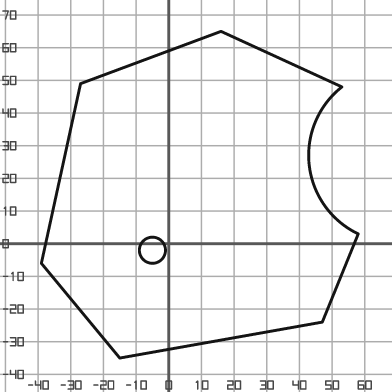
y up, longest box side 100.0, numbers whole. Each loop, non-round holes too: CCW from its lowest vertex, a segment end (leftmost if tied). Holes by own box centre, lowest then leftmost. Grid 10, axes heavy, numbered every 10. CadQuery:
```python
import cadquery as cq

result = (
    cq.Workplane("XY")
    .moveTo(-15.0, -35.0)
    .lineTo(47.0, -24.0)
    .lineTo(58.0, 3.0)
    .threePointArc((43.0, 24.0), (53.0, 48.0))
    .lineTo(16.0, 65.0)
    .lineTo(-27.0, 49.0)
    .lineTo(-39.0, -6.0)
    .close()
    .moveTo(-5.0, -2.0)
    .circle(4.0)
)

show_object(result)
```